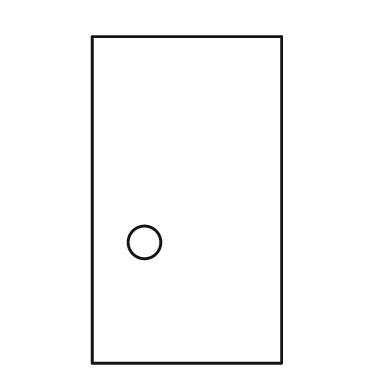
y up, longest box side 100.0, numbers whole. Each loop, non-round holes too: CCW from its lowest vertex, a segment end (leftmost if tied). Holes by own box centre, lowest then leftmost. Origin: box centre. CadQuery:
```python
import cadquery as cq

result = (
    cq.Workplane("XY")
    .moveTo(-29.0, -50.0)
    .lineTo(29.0, -50.0)
    .lineTo(29.0, 50.0)
    .lineTo(-29.0, 50.0)
    .close()
    .moveTo(-13.0, -13.0)
    .circle(5.0)
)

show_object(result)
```